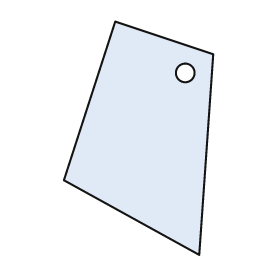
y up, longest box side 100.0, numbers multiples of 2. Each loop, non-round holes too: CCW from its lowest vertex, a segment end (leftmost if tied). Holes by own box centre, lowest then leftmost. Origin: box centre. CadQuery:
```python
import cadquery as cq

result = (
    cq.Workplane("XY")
    .moveTo(26.0, -50.0)
    .lineTo(32.0, 36.0)
    .lineTo(-10.0, 50.0)
    .lineTo(-32.0, -18.0)
    .close()
    .moveTo(20.0, 28.0)
    .circle(4.0)
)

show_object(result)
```